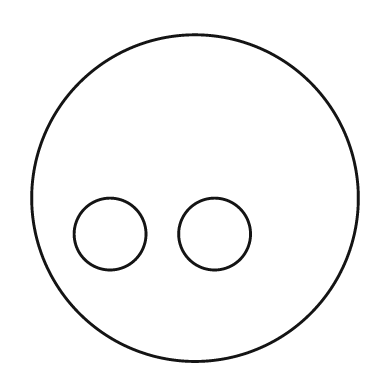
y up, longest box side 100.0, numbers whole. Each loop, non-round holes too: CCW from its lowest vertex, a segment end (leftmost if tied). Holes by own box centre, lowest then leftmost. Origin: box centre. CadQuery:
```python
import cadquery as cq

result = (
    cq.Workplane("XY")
    .moveTo(0.0, 0.0)
    .circle(50.0)
    .moveTo(-26.0, -11.0)
    .circle(11.0)
    .moveTo(6.0, -11.0)
    .circle(11.0)
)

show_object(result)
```